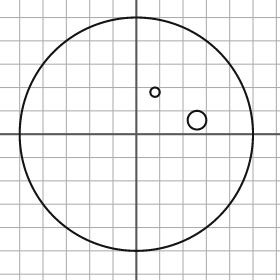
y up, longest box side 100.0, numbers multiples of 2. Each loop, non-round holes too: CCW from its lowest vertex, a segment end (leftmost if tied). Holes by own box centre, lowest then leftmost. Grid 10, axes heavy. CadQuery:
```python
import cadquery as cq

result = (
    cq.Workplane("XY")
    .moveTo(0.0, 0.0)
    .circle(50.0)
    .moveTo(26.0, 6.0)
    .circle(4.0)
    .moveTo(8.0, 18.0)
    .circle(2.0)
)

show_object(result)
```